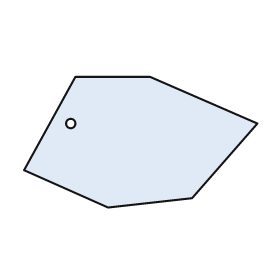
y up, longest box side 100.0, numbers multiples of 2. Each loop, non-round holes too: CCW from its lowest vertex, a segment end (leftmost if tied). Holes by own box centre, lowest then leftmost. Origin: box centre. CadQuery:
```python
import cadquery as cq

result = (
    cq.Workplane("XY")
    .moveTo(-14.0, -28.0)
    .lineTo(22.0, -24.0)
    .lineTo(50.0, 8.0)
    .lineTo(4.0, 28.0)
    .lineTo(-28.0, 28.0)
    .lineTo(-50.0, -12.0)
    .close()
    .moveTo(-30.0, 8.0)
    .circle(2.0)
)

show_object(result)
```